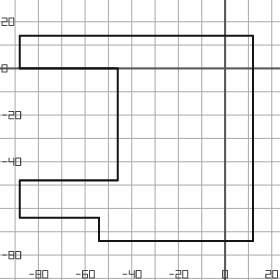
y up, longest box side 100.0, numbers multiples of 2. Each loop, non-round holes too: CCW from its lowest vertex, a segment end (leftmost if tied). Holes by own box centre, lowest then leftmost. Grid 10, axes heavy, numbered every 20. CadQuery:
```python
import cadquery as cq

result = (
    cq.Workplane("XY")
    .moveTo(-54.0, -74.0)
    .lineTo(12.0, -74.0)
    .lineTo(12.0, 14.0)
    .lineTo(-88.0, 14.0)
    .lineTo(-88.0, 0.0)
    .lineTo(-46.0, 0.0)
    .lineTo(-46.0, -48.0)
    .lineTo(-88.0, -48.0)
    .lineTo(-88.0, -64.0)
    .lineTo(-54.0, -64.0)
    .close()
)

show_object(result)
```